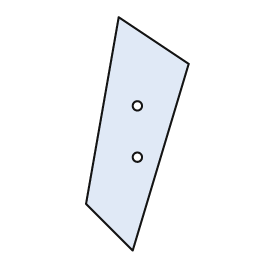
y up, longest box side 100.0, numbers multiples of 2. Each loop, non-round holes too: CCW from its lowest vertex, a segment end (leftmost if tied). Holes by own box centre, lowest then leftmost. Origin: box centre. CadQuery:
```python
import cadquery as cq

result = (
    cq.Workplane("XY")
    .moveTo(-2.0, -50.0)
    .lineTo(22.0, 30.0)
    .lineTo(-8.0, 50.0)
    .lineTo(-22.0, -30.0)
    .close()
    .moveTo(0.0, -10.0)
    .circle(2.0)
    .moveTo(0.0, 12.0)
    .circle(2.0)
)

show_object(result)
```